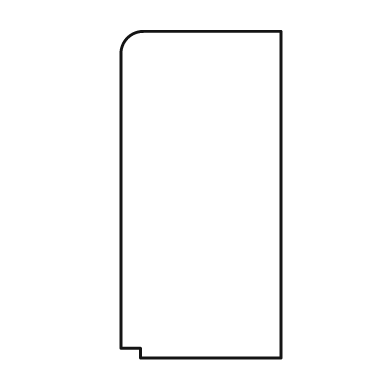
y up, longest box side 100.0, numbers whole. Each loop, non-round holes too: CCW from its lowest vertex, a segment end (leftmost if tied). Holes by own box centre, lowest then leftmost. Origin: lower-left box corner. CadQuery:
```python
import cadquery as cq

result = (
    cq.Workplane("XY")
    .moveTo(6.0, 0.0)
    .lineTo(49.0, 0.0)
    .lineTo(49.0, 100.0)
    .lineTo(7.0, 100.0)
    .threePointArc((2.0, 98.0), (0.0, 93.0))
    .lineTo(0.0, 3.0)
    .lineTo(6.0, 3.0)
    .close()
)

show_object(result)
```